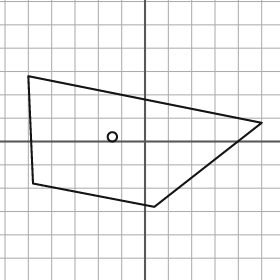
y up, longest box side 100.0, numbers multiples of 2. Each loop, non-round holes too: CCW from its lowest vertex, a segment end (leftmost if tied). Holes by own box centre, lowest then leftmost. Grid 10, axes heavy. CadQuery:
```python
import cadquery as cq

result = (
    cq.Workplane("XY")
    .moveTo(4.0, -28.0)
    .lineTo(50.0, 8.0)
    .lineTo(-50.0, 28.0)
    .lineTo(-48.0, -18.0)
    .close()
    .moveTo(-14.0, 2.0)
    .circle(2.0)
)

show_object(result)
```